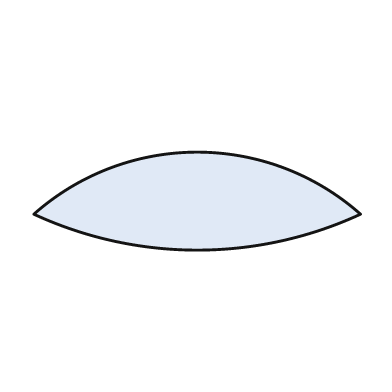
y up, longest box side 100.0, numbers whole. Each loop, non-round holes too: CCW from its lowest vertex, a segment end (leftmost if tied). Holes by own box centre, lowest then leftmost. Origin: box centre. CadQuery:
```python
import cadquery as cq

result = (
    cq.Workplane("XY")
    .moveTo(-50.0, -4.0)
    .threePointArc((0.0, -15.0), (50.0, -4.0))
    .threePointArc((0.0, 15.0), (-50.0, -4.0))
    .close()
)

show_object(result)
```